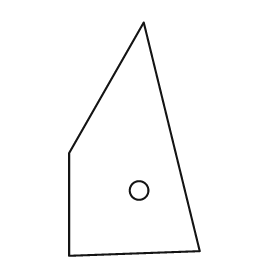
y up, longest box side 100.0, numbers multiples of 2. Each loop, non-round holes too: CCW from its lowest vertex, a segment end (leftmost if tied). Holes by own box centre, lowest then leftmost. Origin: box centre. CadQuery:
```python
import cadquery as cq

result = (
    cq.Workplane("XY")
    .moveTo(-28.0, -50.0)
    .lineTo(28.0, -48.0)
    .lineTo(4.0, 50.0)
    .lineTo(-28.0, -6.0)
    .close()
    .moveTo(2.0, -22.0)
    .circle(4.0)
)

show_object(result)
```